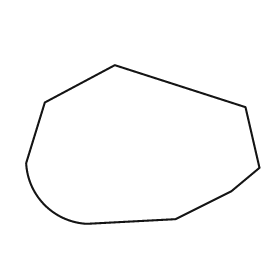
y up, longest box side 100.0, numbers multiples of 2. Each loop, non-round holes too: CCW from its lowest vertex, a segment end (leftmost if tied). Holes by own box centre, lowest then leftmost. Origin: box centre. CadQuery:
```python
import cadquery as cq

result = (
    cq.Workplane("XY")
    .moveTo(-24.0, -34.0)
    .lineTo(14.0, -32.0)
    .lineTo(38.0, -20.0)
    .lineTo(50.0, -10.0)
    .lineTo(44.0, 16.0)
    .lineTo(-12.0, 34.0)
    .lineTo(-42.0, 18.0)
    .lineTo(-50.0, -8.0)
    .threePointArc((-42.0, -26.0), (-24.0, -34.0))
    .close()
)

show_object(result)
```